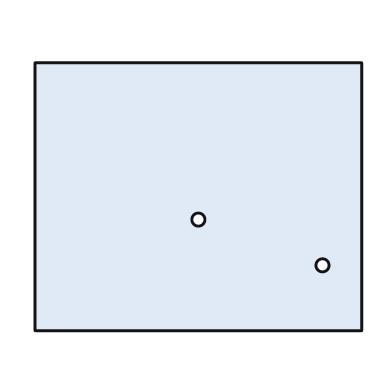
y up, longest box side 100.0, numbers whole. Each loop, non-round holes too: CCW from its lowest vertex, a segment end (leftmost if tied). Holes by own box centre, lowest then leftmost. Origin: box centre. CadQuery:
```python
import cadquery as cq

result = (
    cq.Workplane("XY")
    .moveTo(-50.0, -41.0)
    .lineTo(50.0, -41.0)
    .lineTo(50.0, 41.0)
    .lineTo(-50.0, 41.0)
    .close()
    .moveTo(38.0, -21.0)
    .circle(2.0)
    .moveTo(0.0, -7.0)
    .circle(2.0)
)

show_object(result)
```